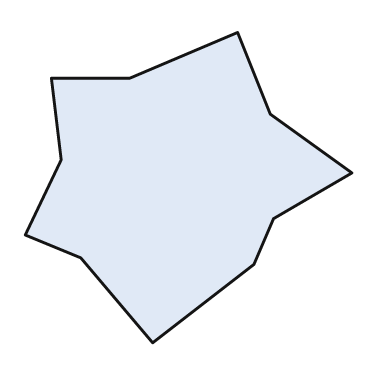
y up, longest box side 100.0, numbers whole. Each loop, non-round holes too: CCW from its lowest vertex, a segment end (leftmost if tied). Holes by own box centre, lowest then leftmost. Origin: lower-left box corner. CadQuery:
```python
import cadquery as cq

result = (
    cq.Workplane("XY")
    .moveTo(39.0, 0.0)
    .lineTo(70.0, 24.0)
    .lineTo(76.0, 38.0)
    .lineTo(100.0, 52.0)
    .lineTo(75.0, 70.0)
    .lineTo(65.0, 95.0)
    .lineTo(32.0, 81.0)
    .lineTo(8.0, 81.0)
    .lineTo(11.0, 56.0)
    .lineTo(0.0, 33.0)
    .lineTo(17.0, 26.0)
    .close()
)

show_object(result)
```